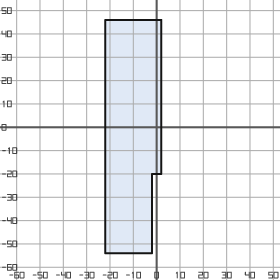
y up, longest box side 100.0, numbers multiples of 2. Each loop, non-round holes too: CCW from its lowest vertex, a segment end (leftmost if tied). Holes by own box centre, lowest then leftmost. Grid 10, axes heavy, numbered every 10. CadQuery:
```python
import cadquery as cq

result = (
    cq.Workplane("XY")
    .moveTo(-22.0, -54.0)
    .lineTo(-2.0, -54.0)
    .lineTo(-2.0, -20.0)
    .lineTo(2.0, -20.0)
    .lineTo(2.0, 46.0)
    .lineTo(-22.0, 46.0)
    .close()
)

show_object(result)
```